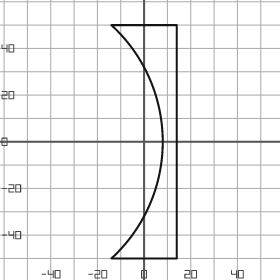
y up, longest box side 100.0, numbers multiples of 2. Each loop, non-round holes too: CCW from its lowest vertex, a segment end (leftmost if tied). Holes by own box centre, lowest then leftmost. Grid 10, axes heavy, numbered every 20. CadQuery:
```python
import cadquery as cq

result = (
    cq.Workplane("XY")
    .moveTo(-14.0, -50.0)
    .lineTo(14.0, -50.0)
    .lineTo(14.0, 50.0)
    .lineTo(-14.0, 50.0)
    .threePointArc((8.0, 0.0), (-14.0, -50.0))
    .close()
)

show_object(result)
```